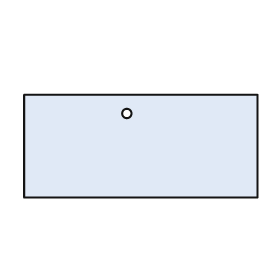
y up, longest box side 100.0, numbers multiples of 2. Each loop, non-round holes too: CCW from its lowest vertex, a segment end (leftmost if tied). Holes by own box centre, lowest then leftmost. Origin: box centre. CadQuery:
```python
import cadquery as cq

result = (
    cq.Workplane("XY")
    .moveTo(-50.0, -22.0)
    .lineTo(50.0, -22.0)
    .lineTo(50.0, 22.0)
    .lineTo(-50.0, 22.0)
    .close()
    .moveTo(-6.0, 14.0)
    .circle(2.0)
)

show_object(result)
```